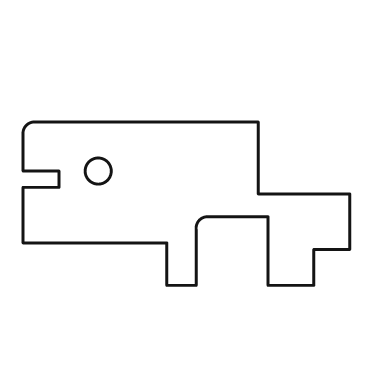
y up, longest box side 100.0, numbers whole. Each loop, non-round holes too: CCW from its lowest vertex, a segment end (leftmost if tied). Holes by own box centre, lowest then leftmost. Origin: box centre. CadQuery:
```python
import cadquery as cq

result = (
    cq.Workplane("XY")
    .moveTo(-6.0, -25.0)
    .lineTo(3.0, -25.0)
    .lineTo(3.0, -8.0)
    .threePointArc((4.0, -5.0), (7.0, -4.0))
    .lineTo(25.0, -4.0)
    .lineTo(25.0, -25.0)
    .lineTo(39.0, -25.0)
    .lineTo(39.0, -14.0)
    .lineTo(50.0, -14.0)
    .lineTo(50.0, 3.0)
    .lineTo(22.0, 3.0)
    .lineTo(22.0, 25.0)
    .lineTo(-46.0, 25.0)
    .threePointArc((-49.0, 24.0), (-50.0, 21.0))
    .lineTo(-50.0, 10.0)
    .lineTo(-39.0, 10.0)
    .lineTo(-39.0, 5.0)
    .lineTo(-50.0, 5.0)
    .lineTo(-50.0, -12.0)
    .lineTo(-6.0, -12.0)
    .close()
    .moveTo(-27.0, 10.0)
    .circle(4.0)
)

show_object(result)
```